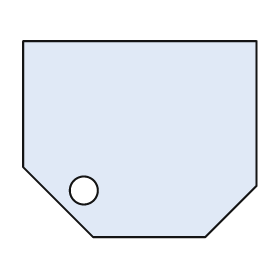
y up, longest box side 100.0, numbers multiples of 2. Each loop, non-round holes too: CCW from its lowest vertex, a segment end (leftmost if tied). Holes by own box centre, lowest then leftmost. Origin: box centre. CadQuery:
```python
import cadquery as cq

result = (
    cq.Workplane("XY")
    .moveTo(-20.0, -42.0)
    .lineTo(28.0, -42.0)
    .lineTo(50.0, -20.0)
    .lineTo(50.0, 42.0)
    .lineTo(-50.0, 42.0)
    .lineTo(-50.0, -12.0)
    .close()
    .moveTo(-24.0, -22.0)
    .circle(6.0)
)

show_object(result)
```